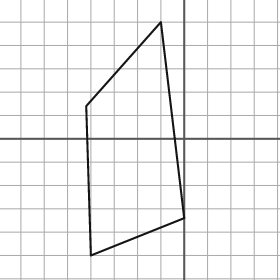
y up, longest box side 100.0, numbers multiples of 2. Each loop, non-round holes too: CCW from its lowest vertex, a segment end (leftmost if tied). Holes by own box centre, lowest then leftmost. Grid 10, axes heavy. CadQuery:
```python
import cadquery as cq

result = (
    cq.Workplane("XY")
    .moveTo(-40.0, -50.0)
    .lineTo(0.0, -34.0)
    .lineTo(-10.0, 50.0)
    .lineTo(-42.0, 14.0)
    .close()
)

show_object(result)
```